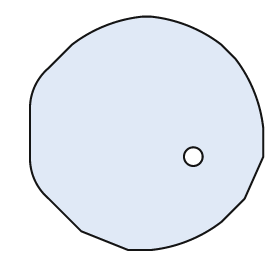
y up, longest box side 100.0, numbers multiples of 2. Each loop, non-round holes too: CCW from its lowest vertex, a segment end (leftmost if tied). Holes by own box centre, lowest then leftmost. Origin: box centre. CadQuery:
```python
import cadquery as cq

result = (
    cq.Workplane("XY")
    .moveTo(-8.0, -50.0)
    .lineTo(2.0, -50.0)
    .threePointArc((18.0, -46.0), (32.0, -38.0))
    .lineTo(42.0, -28.0)
    .lineTo(50.0, -10.0)
    .lineTo(50.0, 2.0)
    .threePointArc((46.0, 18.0), (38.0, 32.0))
    .lineTo(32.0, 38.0)
    .threePointArc((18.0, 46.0), (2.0, 50.0))
    .lineTo(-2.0, 50.0)
    .threePointArc((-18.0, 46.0), (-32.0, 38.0))
    .lineTo(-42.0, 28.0)
    .threePointArc((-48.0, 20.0), (-50.0, 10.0))
    .lineTo(-50.0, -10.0)
    .threePointArc((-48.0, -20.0), (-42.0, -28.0))
    .lineTo(-28.0, -42.0)
    .close()
    .moveTo(20.0, -10.0)
    .circle(4.0)
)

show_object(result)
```